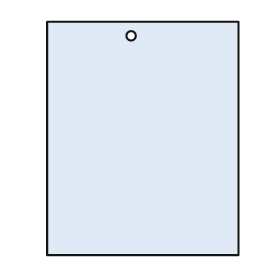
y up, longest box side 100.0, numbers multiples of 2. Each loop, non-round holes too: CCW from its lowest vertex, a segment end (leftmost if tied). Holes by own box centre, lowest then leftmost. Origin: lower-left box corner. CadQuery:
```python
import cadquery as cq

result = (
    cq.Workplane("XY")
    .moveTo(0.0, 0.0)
    .lineTo(82.0, 0.0)
    .lineTo(82.0, 100.0)
    .lineTo(0.0, 100.0)
    .close()
    .moveTo(36.0, 94.0)
    .circle(2.0)
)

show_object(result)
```